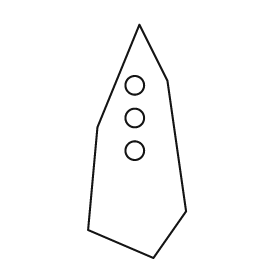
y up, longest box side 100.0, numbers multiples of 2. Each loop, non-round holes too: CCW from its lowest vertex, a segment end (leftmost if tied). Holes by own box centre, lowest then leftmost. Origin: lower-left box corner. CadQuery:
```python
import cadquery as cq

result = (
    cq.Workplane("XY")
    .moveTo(28.0, 0.0)
    .lineTo(42.0, 20.0)
    .lineTo(34.0, 76.0)
    .lineTo(22.0, 100.0)
    .lineTo(4.0, 56.0)
    .lineTo(0.0, 12.0)
    .close()
    .moveTo(20.0, 46.0)
    .circle(4.0)
    .moveTo(20.0, 60.0)
    .circle(4.0)
    .moveTo(20.0, 74.0)
    .circle(4.0)
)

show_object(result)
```